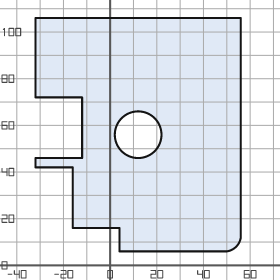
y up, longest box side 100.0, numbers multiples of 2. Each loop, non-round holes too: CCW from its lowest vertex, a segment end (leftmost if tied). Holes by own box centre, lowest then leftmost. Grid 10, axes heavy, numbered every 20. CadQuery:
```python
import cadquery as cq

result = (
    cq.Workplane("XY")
    .moveTo(4.0, 6.0)
    .lineTo(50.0, 6.0)
    .threePointArc((54.0, 8.0), (56.0, 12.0))
    .lineTo(56.0, 106.0)
    .lineTo(-32.0, 106.0)
    .lineTo(-32.0, 72.0)
    .lineTo(-12.0, 72.0)
    .lineTo(-12.0, 46.0)
    .lineTo(-32.0, 46.0)
    .lineTo(-32.0, 42.0)
    .lineTo(-16.0, 42.0)
    .lineTo(-16.0, 16.0)
    .lineTo(4.0, 16.0)
    .close()
    .moveTo(12.0, 56.0)
    .circle(10.0)
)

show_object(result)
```